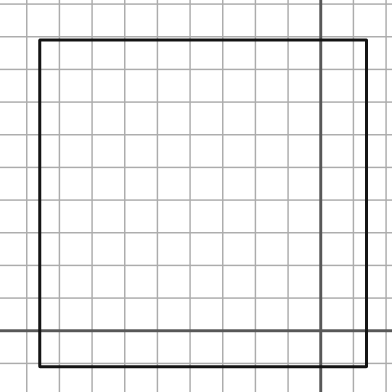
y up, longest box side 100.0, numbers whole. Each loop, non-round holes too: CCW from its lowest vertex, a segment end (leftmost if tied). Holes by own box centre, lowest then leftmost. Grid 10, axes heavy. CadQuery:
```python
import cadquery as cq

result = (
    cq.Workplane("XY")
    .moveTo(-86.0, -11.0)
    .lineTo(14.0, -11.0)
    .lineTo(14.0, 89.0)
    .lineTo(-86.0, 89.0)
    .close()
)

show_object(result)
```